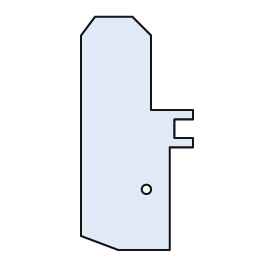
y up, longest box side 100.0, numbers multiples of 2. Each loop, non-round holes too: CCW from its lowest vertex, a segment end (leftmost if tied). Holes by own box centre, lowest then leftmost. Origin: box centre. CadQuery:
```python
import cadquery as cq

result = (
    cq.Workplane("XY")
    .moveTo(-8.0, -50.0)
    .lineTo(14.0, -50.0)
    .lineTo(14.0, -6.0)
    .lineTo(24.0, -6.0)
    .lineTo(24.0, -2.0)
    .lineTo(16.0, -2.0)
    .lineTo(16.0, 6.0)
    .lineTo(24.0, 6.0)
    .lineTo(24.0, 10.0)
    .lineTo(6.0, 10.0)
    .lineTo(6.0, 42.0)
    .lineTo(-2.0, 50.0)
    .lineTo(-18.0, 50.0)
    .lineTo(-24.0, 42.0)
    .lineTo(-24.0, -44.0)
    .close()
    .moveTo(4.0, -24.0)
    .circle(2.0)
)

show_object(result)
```